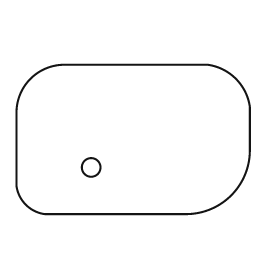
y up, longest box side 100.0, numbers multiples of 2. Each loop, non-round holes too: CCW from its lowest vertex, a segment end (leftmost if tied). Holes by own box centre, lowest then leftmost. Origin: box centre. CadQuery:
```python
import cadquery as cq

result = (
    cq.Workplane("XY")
    .moveTo(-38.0, -32.0)
    .lineTo(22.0, -32.0)
    .threePointArc((42.0, -24.0), (50.0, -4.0))
    .lineTo(50.0, 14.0)
    .threePointArc((44.0, 26.0), (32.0, 32.0))
    .lineTo(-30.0, 32.0)
    .threePointArc((-44.0, 26.0), (-50.0, 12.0))
    .lineTo(-50.0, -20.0)
    .threePointArc((-46.0, -28.0), (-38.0, -32.0))
    .close()
    .moveTo(-18.0, -12.0)
    .circle(4.0)
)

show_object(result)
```